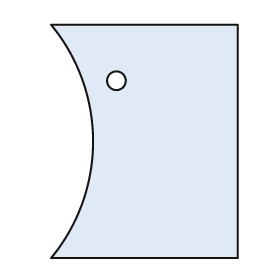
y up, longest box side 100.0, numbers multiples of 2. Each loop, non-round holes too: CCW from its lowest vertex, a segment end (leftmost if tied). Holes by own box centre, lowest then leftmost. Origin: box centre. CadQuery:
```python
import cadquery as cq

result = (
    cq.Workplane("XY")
    .moveTo(-40.0, -50.0)
    .lineTo(40.0, -50.0)
    .lineTo(40.0, 50.0)
    .lineTo(-40.0, 50.0)
    .threePointArc((-22.0, 0.0), (-40.0, -50.0))
    .close()
    .moveTo(-12.0, 26.0)
    .circle(4.0)
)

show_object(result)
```